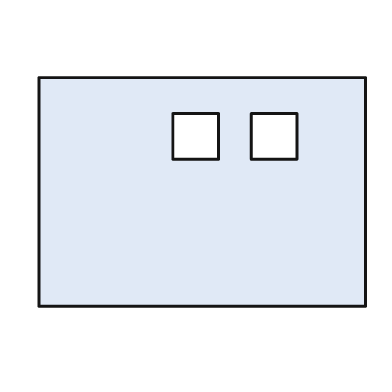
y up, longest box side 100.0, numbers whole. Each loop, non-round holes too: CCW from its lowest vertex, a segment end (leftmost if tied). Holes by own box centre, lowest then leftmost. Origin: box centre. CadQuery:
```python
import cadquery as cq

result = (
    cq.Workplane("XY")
    .moveTo(-50.0, -35.0)
    .lineTo(50.0, -35.0)
    .lineTo(50.0, 35.0)
    .lineTo(-50.0, 35.0)
    .close()
    .moveTo(-9.0, 10.0)
    .lineTo(5.0, 10.0)
    .lineTo(5.0, 24.0)
    .lineTo(-9.0, 24.0)
    .close()
    .moveTo(15.0, 10.0)
    .lineTo(29.0, 10.0)
    .lineTo(29.0, 24.0)
    .lineTo(15.0, 24.0)
    .close()
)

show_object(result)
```